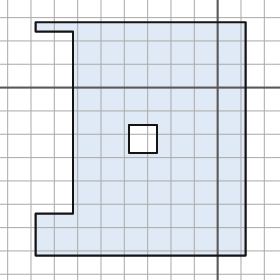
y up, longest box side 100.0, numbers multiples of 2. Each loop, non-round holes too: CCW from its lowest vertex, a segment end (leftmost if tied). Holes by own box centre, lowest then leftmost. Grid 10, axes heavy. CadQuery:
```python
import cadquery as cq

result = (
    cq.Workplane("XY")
    .moveTo(-78.0, -72.0)
    .lineTo(12.0, -72.0)
    .lineTo(12.0, 28.0)
    .lineTo(-78.0, 28.0)
    .lineTo(-78.0, 24.0)
    .lineTo(-62.0, 24.0)
    .lineTo(-62.0, -54.0)
    .lineTo(-78.0, -54.0)
    .close()
    .moveTo(-38.0, -28.0)
    .lineTo(-26.0, -28.0)
    .lineTo(-26.0, -16.0)
    .lineTo(-38.0, -16.0)
    .close()
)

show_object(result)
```